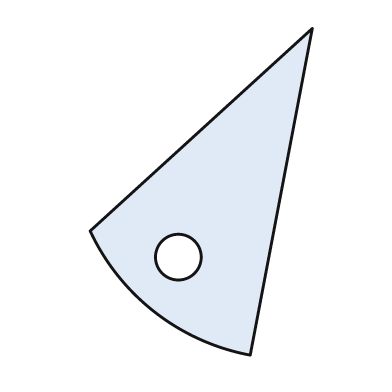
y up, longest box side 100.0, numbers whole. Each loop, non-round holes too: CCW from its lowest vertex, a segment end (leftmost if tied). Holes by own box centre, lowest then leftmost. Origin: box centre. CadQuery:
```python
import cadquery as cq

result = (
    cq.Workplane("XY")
    .moveTo(15.0, -50.0)
    .lineTo(34.0, 50.0)
    .lineTo(-34.0, -12.0)
    .threePointArc((-14.0, -37.0), (15.0, -50.0))
    .close()
    .moveTo(-7.0, -20.0)
    .circle(7.0)
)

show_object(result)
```